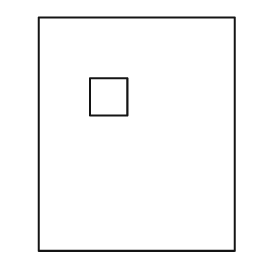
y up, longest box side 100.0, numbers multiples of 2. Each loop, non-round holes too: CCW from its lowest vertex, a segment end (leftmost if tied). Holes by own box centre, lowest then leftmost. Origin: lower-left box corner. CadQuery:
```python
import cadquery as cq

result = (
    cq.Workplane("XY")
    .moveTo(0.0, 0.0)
    .lineTo(84.0, 0.0)
    .lineTo(84.0, 100.0)
    .lineTo(0.0, 100.0)
    .close()
    .moveTo(22.0, 58.0)
    .lineTo(38.0, 58.0)
    .lineTo(38.0, 74.0)
    .lineTo(22.0, 74.0)
    .close()
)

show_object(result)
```